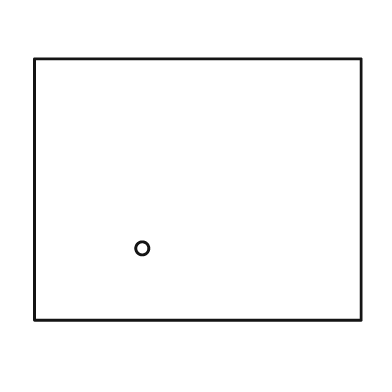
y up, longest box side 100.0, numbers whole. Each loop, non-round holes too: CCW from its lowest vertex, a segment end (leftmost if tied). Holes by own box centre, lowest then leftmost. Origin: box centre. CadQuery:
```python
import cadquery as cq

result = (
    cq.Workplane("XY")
    .moveTo(-50.0, -40.0)
    .lineTo(50.0, -40.0)
    .lineTo(50.0, 40.0)
    .lineTo(-50.0, 40.0)
    .close()
    .moveTo(-17.0, -18.0)
    .circle(2.0)
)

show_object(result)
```